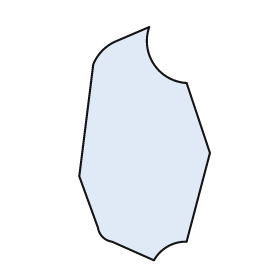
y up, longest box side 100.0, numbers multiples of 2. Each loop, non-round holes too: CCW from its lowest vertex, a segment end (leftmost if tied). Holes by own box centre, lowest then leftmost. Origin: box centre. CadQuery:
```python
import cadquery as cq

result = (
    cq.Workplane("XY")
    .moveTo(4.0, -50.0)
    .threePointArc((10.0, -44.0), (18.0, -42.0))
    .lineTo(28.0, -4.0)
    .lineTo(18.0, 26.0)
    .threePointArc((4.0, 34.0), (2.0, 50.0))
    .lineTo(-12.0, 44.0)
    .threePointArc((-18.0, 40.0), (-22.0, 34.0))
    .lineTo(-28.0, -14.0)
    .lineTo(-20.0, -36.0)
    .threePointArc((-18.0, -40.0), (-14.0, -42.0))
    .close()
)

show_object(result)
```